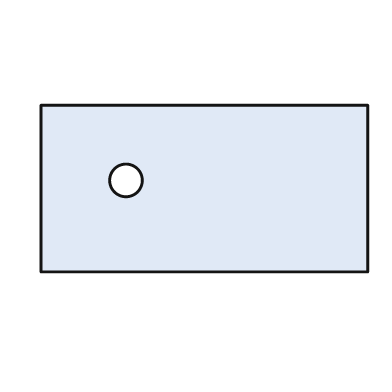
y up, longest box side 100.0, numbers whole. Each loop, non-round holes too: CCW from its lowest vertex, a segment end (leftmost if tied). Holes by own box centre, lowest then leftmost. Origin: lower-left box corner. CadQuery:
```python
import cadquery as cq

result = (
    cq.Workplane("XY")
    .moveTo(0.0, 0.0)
    .lineTo(100.0, 0.0)
    .lineTo(100.0, 51.0)
    .lineTo(0.0, 51.0)
    .close()
    .moveTo(26.0, 28.0)
    .circle(5.0)
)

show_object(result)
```